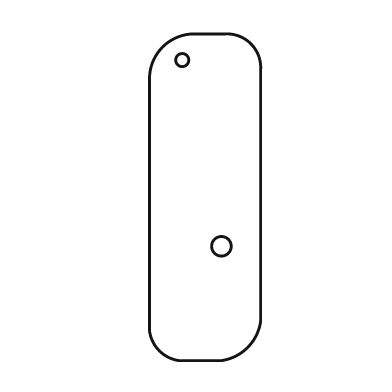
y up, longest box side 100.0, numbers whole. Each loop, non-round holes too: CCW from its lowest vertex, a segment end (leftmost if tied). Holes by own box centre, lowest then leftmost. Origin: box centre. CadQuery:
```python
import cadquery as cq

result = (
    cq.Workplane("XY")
    .moveTo(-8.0, -50.0)
    .lineTo(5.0, -50.0)
    .threePointArc((13.0, -46.0), (17.0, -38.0))
    .lineTo(17.0, 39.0)
    .threePointArc((14.0, 47.0), (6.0, 50.0))
    .lineTo(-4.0, 50.0)
    .threePointArc((-13.0, 46.0), (-17.0, 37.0))
    .lineTo(-17.0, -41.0)
    .threePointArc((-14.0, -47.0), (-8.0, -50.0))
    .close()
    .moveTo(5.0, -15.0)
    .circle(3.0)
    .moveTo(-7.0, 42.0)
    .circle(2.0)
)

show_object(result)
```